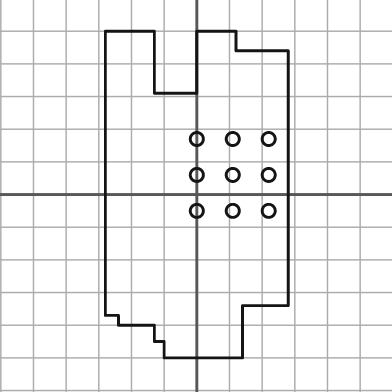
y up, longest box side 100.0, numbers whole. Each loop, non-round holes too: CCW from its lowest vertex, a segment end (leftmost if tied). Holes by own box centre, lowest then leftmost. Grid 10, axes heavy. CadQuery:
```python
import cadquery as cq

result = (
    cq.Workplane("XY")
    .moveTo(-10.0, -50.0)
    .lineTo(14.0, -50.0)
    .lineTo(14.0, -34.0)
    .lineTo(28.0, -34.0)
    .lineTo(28.0, 44.0)
    .lineTo(12.0, 44.0)
    .lineTo(12.0, 50.0)
    .lineTo(0.0, 50.0)
    .lineTo(0.0, 31.0)
    .lineTo(-13.0, 31.0)
    .lineTo(-13.0, 50.0)
    .lineTo(-28.0, 50.0)
    .lineTo(-28.0, -37.0)
    .lineTo(-24.0, -37.0)
    .lineTo(-24.0, -40.0)
    .lineTo(-13.0, -40.0)
    .lineTo(-13.0, -45.0)
    .lineTo(-10.0, -45.0)
    .close()
    .moveTo(0.0, -5.0)
    .circle(2.0)
    .moveTo(11.0, -5.0)
    .circle(2.0)
    .moveTo(22.0, -5.0)
    .circle(2.0)
    .moveTo(0.0, 6.0)
    .circle(2.0)
    .moveTo(11.0, 6.0)
    .circle(2.0)
    .moveTo(22.0, 6.0)
    .circle(2.0)
    .moveTo(0.0, 17.0)
    .circle(2.0)
    .moveTo(11.0, 17.0)
    .circle(2.0)
    .moveTo(22.0, 17.0)
    .circle(2.0)
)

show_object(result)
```